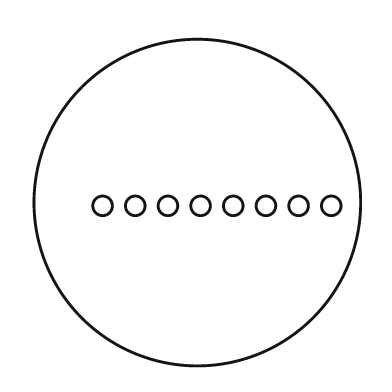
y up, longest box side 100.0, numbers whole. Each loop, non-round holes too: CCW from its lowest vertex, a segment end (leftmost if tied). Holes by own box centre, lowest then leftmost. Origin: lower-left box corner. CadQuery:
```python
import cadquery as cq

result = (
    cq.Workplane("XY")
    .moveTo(50.0, 50.0)
    .circle(50.0)
    .moveTo(21.0, 49.0)
    .circle(3.0)
    .moveTo(31.0, 49.0)
    .circle(3.0)
    .moveTo(41.0, 49.0)
    .circle(3.0)
    .moveTo(51.0, 49.0)
    .circle(3.0)
    .moveTo(61.0, 49.0)
    .circle(3.0)
    .moveTo(71.0, 49.0)
    .circle(3.0)
    .moveTo(81.0, 49.0)
    .circle(3.0)
    .moveTo(91.0, 49.0)
    .circle(3.0)
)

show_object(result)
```